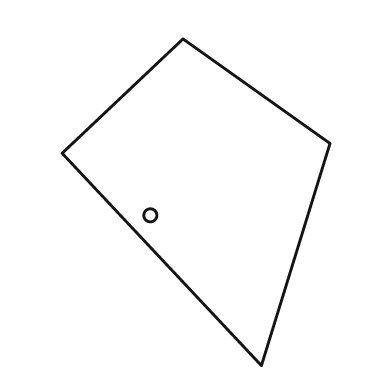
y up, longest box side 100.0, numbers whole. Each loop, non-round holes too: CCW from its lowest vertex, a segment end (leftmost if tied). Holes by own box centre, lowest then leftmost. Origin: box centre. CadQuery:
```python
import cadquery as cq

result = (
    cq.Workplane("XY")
    .moveTo(20.0, -50.0)
    .lineTo(41.0, 18.0)
    .lineTo(-4.0, 50.0)
    .lineTo(-41.0, 15.0)
    .close()
    .moveTo(-14.0, -4.0)
    .circle(2.0)
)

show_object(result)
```